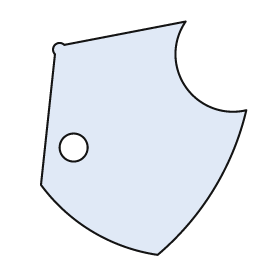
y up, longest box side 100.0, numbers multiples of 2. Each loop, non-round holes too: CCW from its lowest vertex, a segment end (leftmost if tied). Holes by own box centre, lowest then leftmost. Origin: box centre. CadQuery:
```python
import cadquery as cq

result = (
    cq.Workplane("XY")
    .moveTo(6.0, -50.0)
    .threePointArc((30.0, -22.0), (44.0, 12.0))
    .threePointArc((18.0, 22.0), (18.0, 50.0))
    .lineTo(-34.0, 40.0)
    .threePointArc((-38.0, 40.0), (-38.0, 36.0))
    .lineTo(-44.0, -20.0)
    .threePointArc((-22.0, -40.0), (6.0, -50.0))
    .close()
    .moveTo(-30.0, -4.0)
    .circle(6.0)
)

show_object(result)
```